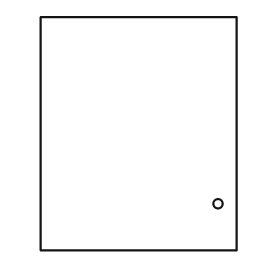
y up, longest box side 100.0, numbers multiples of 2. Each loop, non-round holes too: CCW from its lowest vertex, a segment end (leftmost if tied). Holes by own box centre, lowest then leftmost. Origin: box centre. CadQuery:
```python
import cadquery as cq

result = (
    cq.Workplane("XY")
    .moveTo(-42.0, -50.0)
    .lineTo(42.0, -50.0)
    .lineTo(42.0, 50.0)
    .lineTo(-42.0, 50.0)
    .close()
    .moveTo(34.0, -30.0)
    .circle(2.0)
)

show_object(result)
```